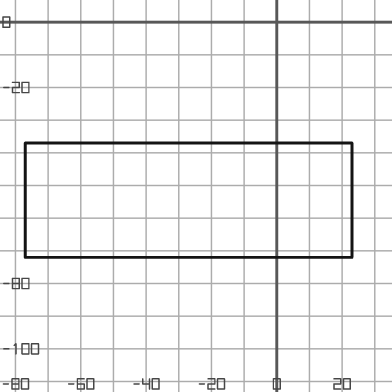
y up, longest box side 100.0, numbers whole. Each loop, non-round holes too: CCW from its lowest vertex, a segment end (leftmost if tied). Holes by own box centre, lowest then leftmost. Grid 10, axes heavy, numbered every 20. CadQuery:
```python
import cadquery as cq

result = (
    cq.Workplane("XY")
    .moveTo(-77.0, -72.0)
    .lineTo(23.0, -72.0)
    .lineTo(23.0, -37.0)
    .lineTo(-77.0, -37.0)
    .close()
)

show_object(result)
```